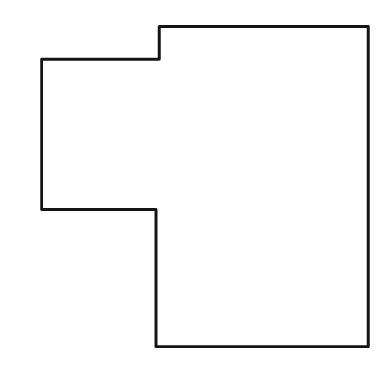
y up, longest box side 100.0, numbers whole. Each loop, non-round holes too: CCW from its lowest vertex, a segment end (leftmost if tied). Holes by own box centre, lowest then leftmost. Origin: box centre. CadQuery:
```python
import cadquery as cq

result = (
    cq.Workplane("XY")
    .moveTo(-15.0, -49.0)
    .lineTo(50.0, -49.0)
    .lineTo(50.0, 49.0)
    .lineTo(-14.0, 49.0)
    .lineTo(-14.0, 39.0)
    .lineTo(-50.0, 39.0)
    .lineTo(-50.0, -7.0)
    .lineTo(-15.0, -7.0)
    .close()
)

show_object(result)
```